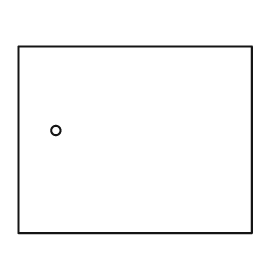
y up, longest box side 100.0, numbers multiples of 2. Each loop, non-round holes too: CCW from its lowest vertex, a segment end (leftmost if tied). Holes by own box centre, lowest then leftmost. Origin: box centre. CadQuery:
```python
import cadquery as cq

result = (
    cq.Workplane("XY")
    .moveTo(-50.0, -40.0)
    .lineTo(50.0, -40.0)
    .lineTo(50.0, 40.0)
    .lineTo(-50.0, 40.0)
    .close()
    .moveTo(-34.0, 4.0)
    .circle(2.0)
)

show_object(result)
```